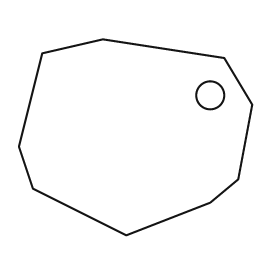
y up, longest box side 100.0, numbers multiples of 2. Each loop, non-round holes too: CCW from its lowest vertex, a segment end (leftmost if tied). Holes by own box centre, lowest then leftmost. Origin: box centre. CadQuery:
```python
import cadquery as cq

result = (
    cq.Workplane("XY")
    .moveTo(-4.0, -42.0)
    .lineTo(32.0, -28.0)
    .lineTo(44.0, -18.0)
    .lineTo(50.0, 14.0)
    .lineTo(38.0, 34.0)
    .lineTo(-14.0, 42.0)
    .lineTo(-40.0, 36.0)
    .lineTo(-50.0, -4.0)
    .lineTo(-44.0, -22.0)
    .close()
    .moveTo(32.0, 18.0)
    .circle(6.0)
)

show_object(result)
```